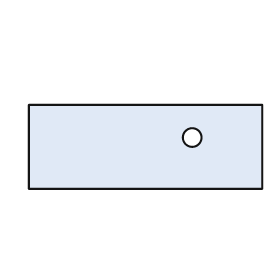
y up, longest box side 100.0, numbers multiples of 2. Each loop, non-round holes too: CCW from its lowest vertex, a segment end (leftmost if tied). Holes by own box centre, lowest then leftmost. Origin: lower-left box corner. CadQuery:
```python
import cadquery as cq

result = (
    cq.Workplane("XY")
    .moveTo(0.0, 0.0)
    .lineTo(100.0, 0.0)
    .lineTo(100.0, 36.0)
    .lineTo(0.0, 36.0)
    .close()
    .moveTo(70.0, 22.0)
    .circle(4.0)
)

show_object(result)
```